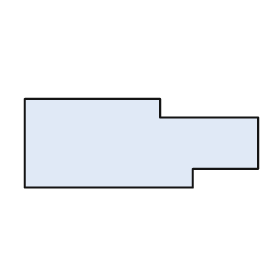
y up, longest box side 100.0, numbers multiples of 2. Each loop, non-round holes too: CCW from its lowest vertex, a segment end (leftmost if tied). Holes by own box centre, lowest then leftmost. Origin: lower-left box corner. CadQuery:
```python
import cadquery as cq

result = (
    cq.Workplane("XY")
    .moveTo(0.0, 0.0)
    .lineTo(72.0, 0.0)
    .lineTo(72.0, 8.0)
    .lineTo(100.0, 8.0)
    .lineTo(100.0, 30.0)
    .lineTo(58.0, 30.0)
    .lineTo(58.0, 38.0)
    .lineTo(0.0, 38.0)
    .close()
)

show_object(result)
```